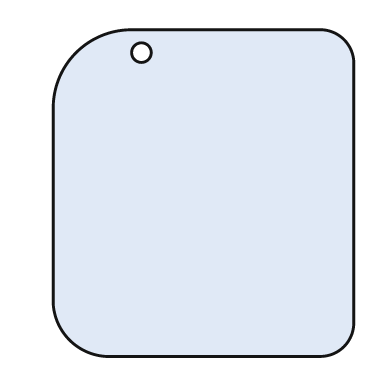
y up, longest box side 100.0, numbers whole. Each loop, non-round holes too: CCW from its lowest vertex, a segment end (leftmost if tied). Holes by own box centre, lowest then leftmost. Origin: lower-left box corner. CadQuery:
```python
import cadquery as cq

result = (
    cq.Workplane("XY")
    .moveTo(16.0, 0.0)
    .lineTo(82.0, 0.0)
    .threePointArc((89.0, 3.0), (92.0, 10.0))
    .lineTo(92.0, 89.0)
    .threePointArc((89.0, 97.0), (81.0, 100.0))
    .lineTo(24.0, 100.0)
    .threePointArc((7.0, 93.0), (0.0, 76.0))
    .lineTo(0.0, 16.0)
    .threePointArc((5.0, 5.0), (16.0, 0.0))
    .close()
    .moveTo(27.0, 93.0)
    .circle(3.0)
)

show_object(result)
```